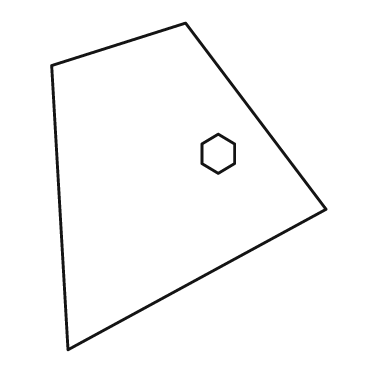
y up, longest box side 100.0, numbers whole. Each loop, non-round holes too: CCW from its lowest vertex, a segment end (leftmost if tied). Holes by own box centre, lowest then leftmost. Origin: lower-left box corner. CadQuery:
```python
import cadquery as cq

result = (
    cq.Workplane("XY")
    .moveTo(5.0, 0.0)
    .lineTo(84.0, 43.0)
    .lineTo(41.0, 100.0)
    .lineTo(0.0, 87.0)
    .close()
    .moveTo(51.0, 54.0)
    .lineTo(56.0, 57.0)
    .lineTo(56.0, 63.0)
    .lineTo(51.0, 66.0)
    .lineTo(46.0, 63.0)
    .lineTo(46.0, 57.0)
    .close()
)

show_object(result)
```